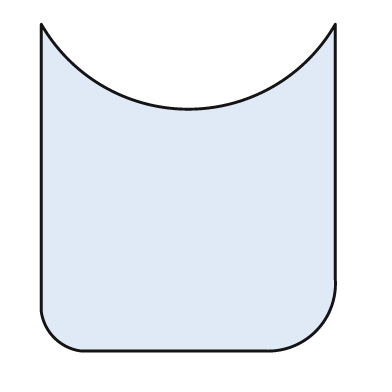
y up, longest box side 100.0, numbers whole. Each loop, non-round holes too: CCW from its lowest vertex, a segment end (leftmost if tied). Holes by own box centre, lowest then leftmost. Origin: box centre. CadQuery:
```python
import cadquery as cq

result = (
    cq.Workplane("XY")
    .moveTo(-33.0, -50.0)
    .lineTo(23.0, -50.0)
    .threePointArc((39.0, -44.0), (45.0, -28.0))
    .lineTo(45.0, 50.0)
    .threePointArc((0.0, 24.0), (-45.0, 50.0))
    .lineTo(-45.0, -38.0)
    .threePointArc((-41.0, -46.0), (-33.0, -50.0))
    .close()
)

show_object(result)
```